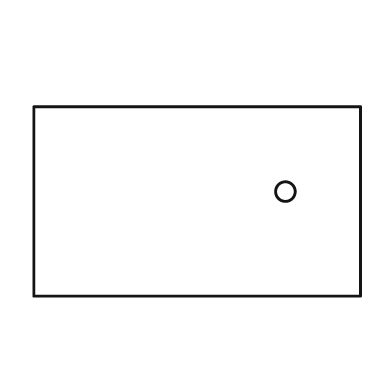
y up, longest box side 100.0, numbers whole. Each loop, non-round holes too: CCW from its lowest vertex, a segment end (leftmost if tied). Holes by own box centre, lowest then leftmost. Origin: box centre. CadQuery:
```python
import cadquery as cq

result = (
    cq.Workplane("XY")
    .moveTo(-50.0, -29.0)
    .lineTo(50.0, -29.0)
    .lineTo(50.0, 29.0)
    .lineTo(-50.0, 29.0)
    .close()
    .moveTo(27.0, 3.0)
    .circle(3.0)
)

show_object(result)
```